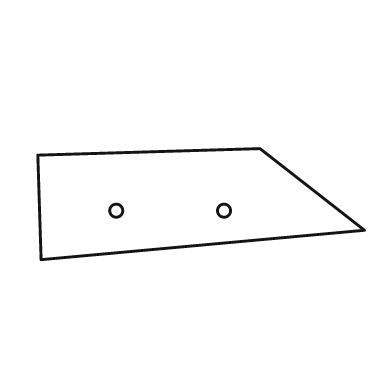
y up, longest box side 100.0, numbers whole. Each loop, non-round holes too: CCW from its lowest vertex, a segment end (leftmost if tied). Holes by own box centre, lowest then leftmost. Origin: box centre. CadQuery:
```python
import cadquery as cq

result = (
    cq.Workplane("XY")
    .moveTo(-49.0, -17.0)
    .lineTo(50.0, -8.0)
    .lineTo(18.0, 17.0)
    .lineTo(-50.0, 15.0)
    .close()
    .moveTo(-26.0, -2.0)
    .circle(2.0)
    .moveTo(7.0, -2.0)
    .circle(2.0)
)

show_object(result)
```